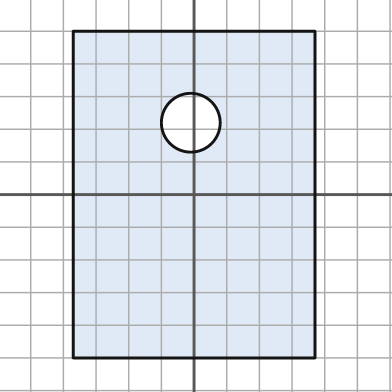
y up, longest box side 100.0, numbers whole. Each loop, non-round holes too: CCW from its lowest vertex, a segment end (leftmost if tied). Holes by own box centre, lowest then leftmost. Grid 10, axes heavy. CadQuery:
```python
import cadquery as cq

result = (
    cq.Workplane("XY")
    .moveTo(-37.0, -50.0)
    .lineTo(37.0, -50.0)
    .lineTo(37.0, 50.0)
    .lineTo(-37.0, 50.0)
    .close()
    .moveTo(-1.0, 22.0)
    .circle(9.0)
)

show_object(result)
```